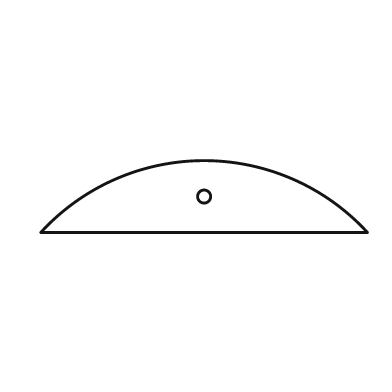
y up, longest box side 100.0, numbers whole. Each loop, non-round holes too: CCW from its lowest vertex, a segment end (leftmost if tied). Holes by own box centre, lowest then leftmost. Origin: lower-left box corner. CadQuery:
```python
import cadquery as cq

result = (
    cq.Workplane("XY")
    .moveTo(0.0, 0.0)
    .lineTo(100.0, 0.0)
    .threePointArc((50.0, 22.0), (0.0, 0.0))
    .close()
    .moveTo(50.0, 11.0)
    .circle(2.0)
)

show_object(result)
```